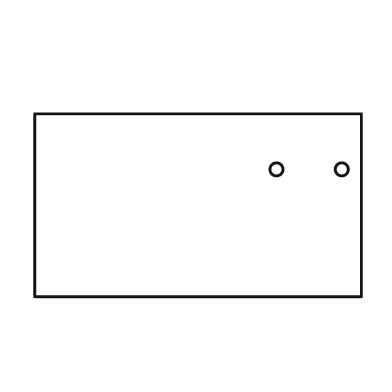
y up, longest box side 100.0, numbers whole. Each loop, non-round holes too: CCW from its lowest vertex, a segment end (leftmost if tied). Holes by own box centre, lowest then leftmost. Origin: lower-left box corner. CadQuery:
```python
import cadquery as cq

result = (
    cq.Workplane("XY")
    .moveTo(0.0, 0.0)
    .lineTo(100.0, 0.0)
    .lineTo(100.0, 56.0)
    .lineTo(0.0, 56.0)
    .close()
    .moveTo(74.0, 39.0)
    .circle(2.0)
    .moveTo(94.0, 39.0)
    .circle(2.0)
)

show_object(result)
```